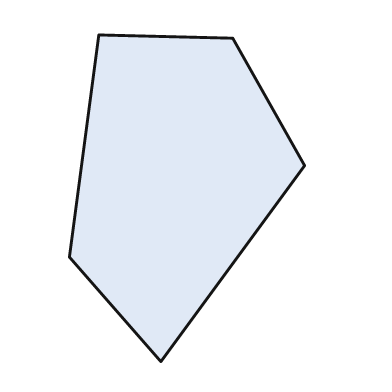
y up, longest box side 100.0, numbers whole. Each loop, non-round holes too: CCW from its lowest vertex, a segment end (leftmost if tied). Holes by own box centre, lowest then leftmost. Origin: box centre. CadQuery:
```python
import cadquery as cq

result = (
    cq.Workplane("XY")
    .moveTo(-8.0, -50.0)
    .lineTo(36.0, 10.0)
    .lineTo(14.0, 49.0)
    .lineTo(-27.0, 50.0)
    .lineTo(-36.0, -18.0)
    .close()
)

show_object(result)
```